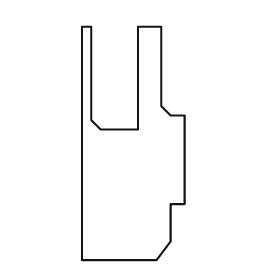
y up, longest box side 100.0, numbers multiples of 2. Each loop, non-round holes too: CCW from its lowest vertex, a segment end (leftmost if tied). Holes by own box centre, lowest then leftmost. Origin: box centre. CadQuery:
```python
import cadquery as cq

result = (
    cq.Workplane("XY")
    .moveTo(-22.0, -50.0)
    .lineTo(10.0, -50.0)
    .lineTo(16.0, -42.0)
    .lineTo(16.0, -26.0)
    .lineTo(22.0, -26.0)
    .lineTo(22.0, 12.0)
    .lineTo(16.0, 12.0)
    .lineTo(12.0, 16.0)
    .lineTo(12.0, 50.0)
    .lineTo(2.0, 50.0)
    .lineTo(2.0, 6.0)
    .lineTo(-14.0, 6.0)
    .lineTo(-18.0, 10.0)
    .lineTo(-18.0, 50.0)
    .lineTo(-22.0, 50.0)
    .close()
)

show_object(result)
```